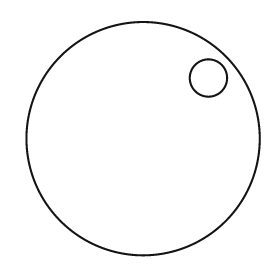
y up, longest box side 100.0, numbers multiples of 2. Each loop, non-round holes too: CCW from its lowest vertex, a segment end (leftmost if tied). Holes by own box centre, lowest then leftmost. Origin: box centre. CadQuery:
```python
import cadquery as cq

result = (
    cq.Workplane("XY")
    .moveTo(0.0, 0.0)
    .circle(50.0)
    .moveTo(28.0, 26.0)
    .circle(8.0)
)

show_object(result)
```